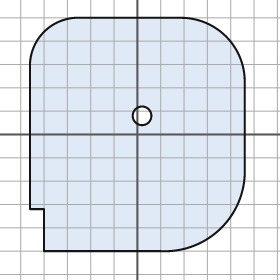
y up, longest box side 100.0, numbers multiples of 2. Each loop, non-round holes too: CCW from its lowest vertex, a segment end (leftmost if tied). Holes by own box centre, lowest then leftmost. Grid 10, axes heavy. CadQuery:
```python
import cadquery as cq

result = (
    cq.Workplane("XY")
    .moveTo(-40.0, -50.0)
    .lineTo(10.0, -50.0)
    .threePointArc((36.0, -40.0), (46.0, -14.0))
    .lineTo(46.0, 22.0)
    .threePointArc((38.0, 42.0), (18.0, 50.0))
    .lineTo(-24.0, 50.0)
    .threePointArc((-40.0, 44.0), (-46.0, 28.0))
    .lineTo(-46.0, -32.0)
    .lineTo(-40.0, -32.0)
    .close()
    .moveTo(2.0, 8.0)
    .circle(4.0)
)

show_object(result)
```